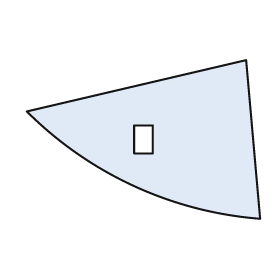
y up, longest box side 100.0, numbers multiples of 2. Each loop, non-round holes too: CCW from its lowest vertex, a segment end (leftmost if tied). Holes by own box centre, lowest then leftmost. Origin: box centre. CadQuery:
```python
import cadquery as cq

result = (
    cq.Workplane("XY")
    .moveTo(50.0, -34.0)
    .lineTo(44.0, 34.0)
    .lineTo(-50.0, 12.0)
    .threePointArc((-4.0, -20.0), (50.0, -34.0))
    .close()
    .moveTo(-4.0, -6.0)
    .lineTo(4.0, -6.0)
    .lineTo(4.0, 6.0)
    .lineTo(-4.0, 6.0)
    .close()
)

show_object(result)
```